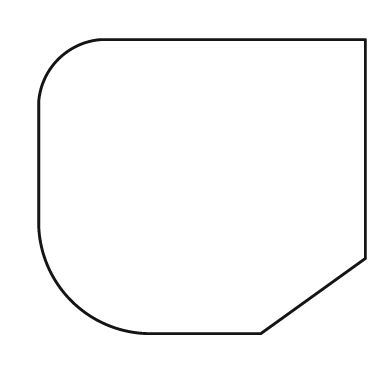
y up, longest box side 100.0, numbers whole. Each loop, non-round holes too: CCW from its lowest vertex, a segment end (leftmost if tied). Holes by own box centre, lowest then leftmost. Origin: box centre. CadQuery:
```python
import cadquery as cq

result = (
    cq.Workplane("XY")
    .moveTo(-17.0, -45.0)
    .lineTo(18.0, -45.0)
    .lineTo(50.0, -22.0)
    .lineTo(50.0, 45.0)
    .lineTo(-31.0, 45.0)
    .threePointArc((-44.0, 39.0), (-50.0, 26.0))
    .lineTo(-50.0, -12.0)
    .threePointArc((-40.0, -35.0), (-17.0, -45.0))
    .close()
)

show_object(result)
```